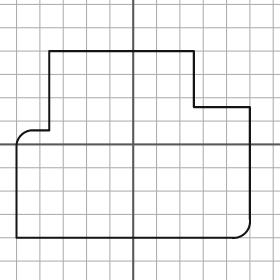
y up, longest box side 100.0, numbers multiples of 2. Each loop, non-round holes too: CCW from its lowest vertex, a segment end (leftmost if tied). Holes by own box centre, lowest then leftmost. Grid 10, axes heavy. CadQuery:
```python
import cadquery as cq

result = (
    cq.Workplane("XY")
    .moveTo(-50.0, -40.0)
    .lineTo(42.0, -40.0)
    .threePointArc((48.0, -38.0), (50.0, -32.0))
    .lineTo(50.0, 16.0)
    .lineTo(26.0, 16.0)
    .lineTo(26.0, 40.0)
    .lineTo(-36.0, 40.0)
    .lineTo(-36.0, 6.0)
    .lineTo(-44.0, 6.0)
    .threePointArc((-48.0, 4.0), (-50.0, 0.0))
    .close()
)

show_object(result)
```